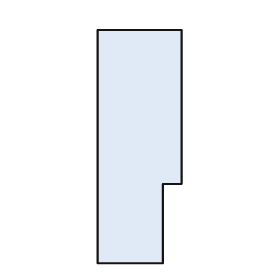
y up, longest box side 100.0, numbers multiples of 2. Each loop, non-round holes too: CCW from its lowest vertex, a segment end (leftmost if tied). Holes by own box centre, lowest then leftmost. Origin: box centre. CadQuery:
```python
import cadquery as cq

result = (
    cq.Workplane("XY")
    .moveTo(-18.0, -50.0)
    .lineTo(10.0, -50.0)
    .lineTo(10.0, -16.0)
    .lineTo(18.0, -16.0)
    .lineTo(18.0, 50.0)
    .lineTo(-18.0, 50.0)
    .close()
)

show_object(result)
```